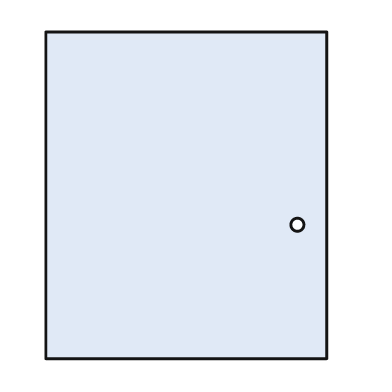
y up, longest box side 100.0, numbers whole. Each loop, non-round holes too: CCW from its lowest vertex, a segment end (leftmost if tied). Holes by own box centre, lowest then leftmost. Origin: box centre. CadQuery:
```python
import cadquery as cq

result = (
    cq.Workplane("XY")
    .moveTo(-43.0, -50.0)
    .lineTo(43.0, -50.0)
    .lineTo(43.0, 50.0)
    .lineTo(-43.0, 50.0)
    .close()
    .moveTo(34.0, -9.0)
    .circle(2.0)
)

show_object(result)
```